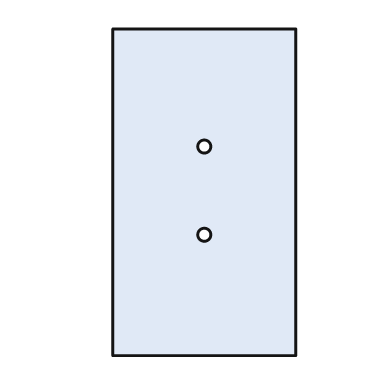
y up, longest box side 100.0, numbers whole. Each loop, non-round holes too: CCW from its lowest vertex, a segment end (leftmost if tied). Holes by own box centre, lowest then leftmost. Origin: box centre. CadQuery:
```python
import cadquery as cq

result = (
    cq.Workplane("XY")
    .moveTo(-28.0, -50.0)
    .lineTo(28.0, -50.0)
    .lineTo(28.0, 50.0)
    .lineTo(-28.0, 50.0)
    .close()
    .moveTo(0.0, -13.0)
    .circle(2.0)
    .moveTo(0.0, 14.0)
    .circle(2.0)
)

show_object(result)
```